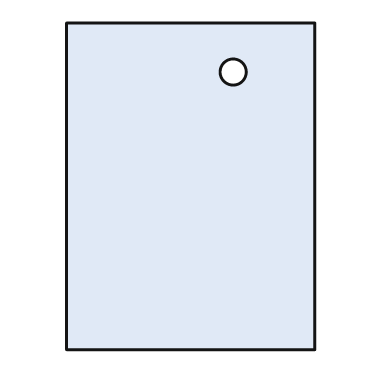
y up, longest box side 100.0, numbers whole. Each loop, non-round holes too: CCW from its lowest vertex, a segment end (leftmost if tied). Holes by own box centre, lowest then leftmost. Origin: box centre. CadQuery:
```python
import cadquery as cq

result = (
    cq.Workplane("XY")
    .moveTo(-38.0, -50.0)
    .lineTo(38.0, -50.0)
    .lineTo(38.0, 50.0)
    .lineTo(-38.0, 50.0)
    .close()
    .moveTo(13.0, 35.0)
    .circle(4.0)
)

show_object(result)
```